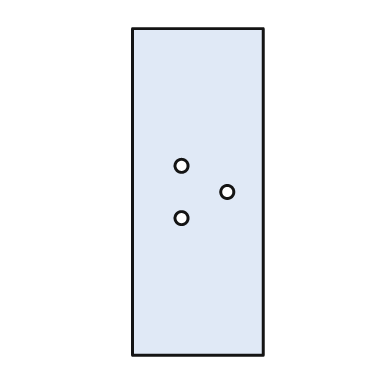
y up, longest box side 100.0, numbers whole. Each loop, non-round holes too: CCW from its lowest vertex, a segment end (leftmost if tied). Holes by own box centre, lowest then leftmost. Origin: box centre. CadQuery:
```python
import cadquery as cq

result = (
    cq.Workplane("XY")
    .moveTo(-20.0, -50.0)
    .lineTo(20.0, -50.0)
    .lineTo(20.0, 50.0)
    .lineTo(-20.0, 50.0)
    .close()
    .moveTo(-5.0, -8.0)
    .circle(2.0)
    .moveTo(9.0, 0.0)
    .circle(2.0)
    .moveTo(-5.0, 8.0)
    .circle(2.0)
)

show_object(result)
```